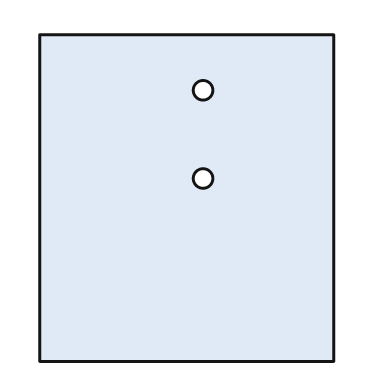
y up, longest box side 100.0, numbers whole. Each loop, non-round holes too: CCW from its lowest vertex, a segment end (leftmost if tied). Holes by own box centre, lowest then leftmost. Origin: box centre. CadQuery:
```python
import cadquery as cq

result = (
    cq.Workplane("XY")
    .moveTo(-45.0, -50.0)
    .lineTo(45.0, -50.0)
    .lineTo(45.0, 50.0)
    .lineTo(-45.0, 50.0)
    .close()
    .moveTo(5.0, 6.0)
    .circle(3.0)
    .moveTo(5.0, 33.0)
    .circle(3.0)
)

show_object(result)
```